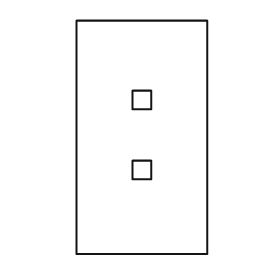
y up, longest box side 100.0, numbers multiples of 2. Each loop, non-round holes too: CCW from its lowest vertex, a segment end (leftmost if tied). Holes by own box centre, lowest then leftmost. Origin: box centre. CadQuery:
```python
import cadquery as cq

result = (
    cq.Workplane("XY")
    .moveTo(-28.0, -50.0)
    .lineTo(28.0, -50.0)
    .lineTo(28.0, 50.0)
    .lineTo(-28.0, 50.0)
    .close()
    .moveTo(-4.0, -18.0)
    .lineTo(4.0, -18.0)
    .lineTo(4.0, -10.0)
    .lineTo(-4.0, -10.0)
    .close()
    .moveTo(-4.0, 12.0)
    .lineTo(4.0, 12.0)
    .lineTo(4.0, 20.0)
    .lineTo(-4.0, 20.0)
    .close()
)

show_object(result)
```